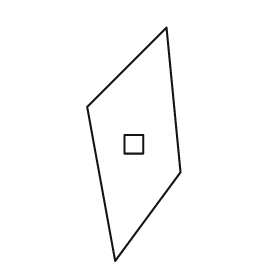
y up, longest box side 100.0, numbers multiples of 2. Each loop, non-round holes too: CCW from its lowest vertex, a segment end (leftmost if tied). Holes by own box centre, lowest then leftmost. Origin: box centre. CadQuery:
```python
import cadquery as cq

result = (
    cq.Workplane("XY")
    .moveTo(-8.0, -50.0)
    .lineTo(20.0, -12.0)
    .lineTo(14.0, 50.0)
    .lineTo(-20.0, 16.0)
    .close()
    .moveTo(-4.0, -4.0)
    .lineTo(4.0, -4.0)
    .lineTo(4.0, 4.0)
    .lineTo(-4.0, 4.0)
    .close()
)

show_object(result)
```